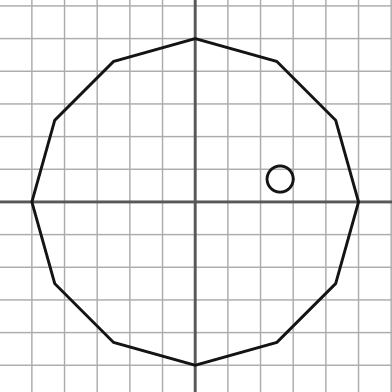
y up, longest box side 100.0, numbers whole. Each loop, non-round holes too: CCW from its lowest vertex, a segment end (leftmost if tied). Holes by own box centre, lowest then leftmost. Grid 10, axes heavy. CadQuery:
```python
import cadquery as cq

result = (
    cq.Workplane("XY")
    .moveTo(0.0, -50.0)
    .lineTo(25.0, -43.0)
    .lineTo(43.0, -25.0)
    .lineTo(50.0, 0.0)
    .lineTo(43.0, 25.0)
    .lineTo(25.0, 43.0)
    .lineTo(0.0, 50.0)
    .lineTo(-25.0, 43.0)
    .lineTo(-43.0, 25.0)
    .lineTo(-50.0, 0.0)
    .lineTo(-43.0, -25.0)
    .lineTo(-25.0, -43.0)
    .close()
    .moveTo(26.0, 7.0)
    .circle(4.0)
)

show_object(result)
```